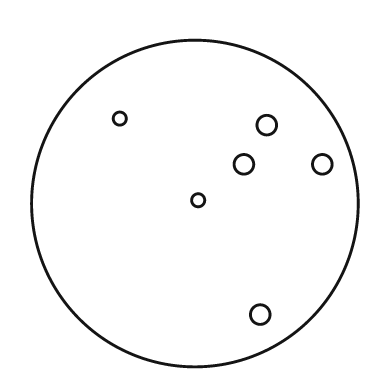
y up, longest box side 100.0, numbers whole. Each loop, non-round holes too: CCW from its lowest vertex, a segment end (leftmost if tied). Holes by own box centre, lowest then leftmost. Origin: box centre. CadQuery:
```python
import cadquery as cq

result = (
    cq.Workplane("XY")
    .moveTo(0.0, 0.0)
    .circle(50.0)
    .moveTo(20.0, -34.0)
    .circle(3.0)
    .moveTo(1.0, 1.0)
    .circle(2.0)
    .moveTo(15.0, 12.0)
    .circle(3.0)
    .moveTo(39.0, 12.0)
    .circle(3.0)
    .moveTo(22.0, 24.0)
    .circle(3.0)
    .moveTo(-23.0, 26.0)
    .circle(2.0)
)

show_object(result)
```